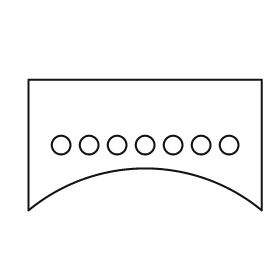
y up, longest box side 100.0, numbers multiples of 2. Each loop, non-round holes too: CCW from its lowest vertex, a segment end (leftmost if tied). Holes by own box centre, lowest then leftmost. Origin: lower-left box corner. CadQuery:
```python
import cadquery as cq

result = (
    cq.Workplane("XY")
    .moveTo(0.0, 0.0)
    .threePointArc((50.0, 18.0), (100.0, 0.0))
    .lineTo(100.0, 56.0)
    .lineTo(0.0, 56.0)
    .close()
    .moveTo(14.0, 28.0)
    .circle(4.0)
    .moveTo(26.0, 28.0)
    .circle(4.0)
    .moveTo(38.0, 28.0)
    .circle(4.0)
    .moveTo(50.0, 28.0)
    .circle(4.0)
    .moveTo(62.0, 28.0)
    .circle(4.0)
    .moveTo(74.0, 28.0)
    .circle(4.0)
    .moveTo(86.0, 28.0)
    .circle(4.0)
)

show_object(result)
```